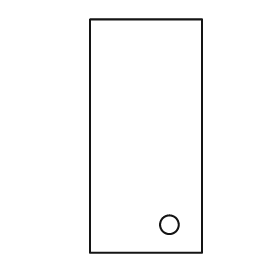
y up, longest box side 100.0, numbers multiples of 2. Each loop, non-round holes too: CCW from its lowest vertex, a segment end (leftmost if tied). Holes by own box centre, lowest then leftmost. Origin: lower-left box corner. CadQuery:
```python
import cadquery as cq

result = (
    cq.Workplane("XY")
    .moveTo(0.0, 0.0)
    .lineTo(48.0, 0.0)
    .lineTo(48.0, 100.0)
    .lineTo(0.0, 100.0)
    .close()
    .moveTo(34.0, 12.0)
    .circle(4.0)
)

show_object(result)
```